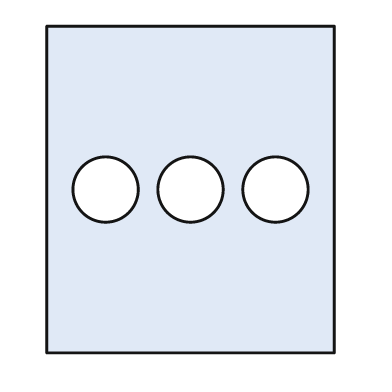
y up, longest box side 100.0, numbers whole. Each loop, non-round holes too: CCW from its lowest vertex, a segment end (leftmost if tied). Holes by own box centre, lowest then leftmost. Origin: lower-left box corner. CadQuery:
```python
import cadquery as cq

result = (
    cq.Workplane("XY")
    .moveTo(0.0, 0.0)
    .lineTo(88.0, 0.0)
    .lineTo(88.0, 100.0)
    .lineTo(0.0, 100.0)
    .close()
    .moveTo(18.0, 50.0)
    .circle(10.0)
    .moveTo(44.0, 50.0)
    .circle(10.0)
    .moveTo(70.0, 50.0)
    .circle(10.0)
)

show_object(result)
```